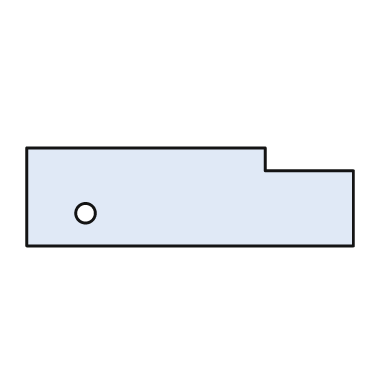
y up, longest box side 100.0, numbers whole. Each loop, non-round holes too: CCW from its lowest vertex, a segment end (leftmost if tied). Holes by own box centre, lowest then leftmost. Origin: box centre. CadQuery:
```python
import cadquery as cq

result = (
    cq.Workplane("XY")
    .moveTo(-50.0, -15.0)
    .lineTo(50.0, -15.0)
    .lineTo(50.0, 8.0)
    .lineTo(23.0, 8.0)
    .lineTo(23.0, 15.0)
    .lineTo(-50.0, 15.0)
    .close()
    .moveTo(-32.0, -5.0)
    .circle(3.0)
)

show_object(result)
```